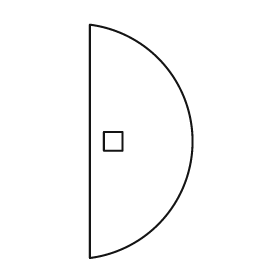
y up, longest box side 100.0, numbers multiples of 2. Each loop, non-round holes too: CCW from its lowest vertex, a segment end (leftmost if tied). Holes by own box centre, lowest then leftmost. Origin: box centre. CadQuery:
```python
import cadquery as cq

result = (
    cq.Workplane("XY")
    .moveTo(-22.0, -50.0)
    .threePointArc((22.0, 0.0), (-22.0, 50.0))
    .close()
    .moveTo(-16.0, -4.0)
    .lineTo(-8.0, -4.0)
    .lineTo(-8.0, 4.0)
    .lineTo(-16.0, 4.0)
    .close()
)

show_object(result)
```